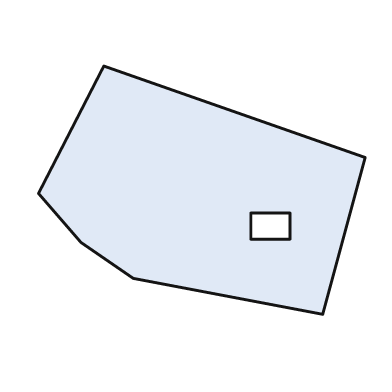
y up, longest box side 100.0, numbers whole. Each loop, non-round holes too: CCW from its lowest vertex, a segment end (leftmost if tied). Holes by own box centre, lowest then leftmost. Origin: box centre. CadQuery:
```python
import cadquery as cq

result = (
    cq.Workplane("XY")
    .moveTo(37.0, -38.0)
    .lineTo(50.0, 10.0)
    .lineTo(-30.0, 38.0)
    .lineTo(-50.0, -1.0)
    .lineTo(-37.0, -16.0)
    .lineTo(-21.0, -27.0)
    .close()
    .moveTo(15.0, -15.0)
    .lineTo(27.0, -15.0)
    .lineTo(27.0, -7.0)
    .lineTo(15.0, -7.0)
    .close()
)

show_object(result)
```